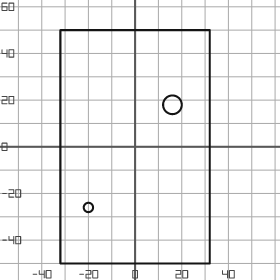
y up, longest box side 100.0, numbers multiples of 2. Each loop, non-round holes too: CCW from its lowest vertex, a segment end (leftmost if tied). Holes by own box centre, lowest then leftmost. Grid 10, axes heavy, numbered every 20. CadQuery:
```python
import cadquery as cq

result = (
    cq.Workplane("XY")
    .moveTo(-32.0, -50.0)
    .lineTo(32.0, -50.0)
    .lineTo(32.0, 50.0)
    .lineTo(-32.0, 50.0)
    .close()
    .moveTo(-20.0, -26.0)
    .circle(2.0)
    .moveTo(16.0, 18.0)
    .circle(4.0)
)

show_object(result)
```